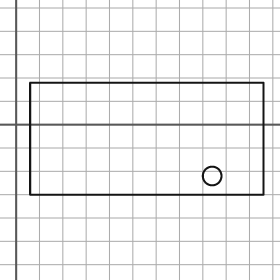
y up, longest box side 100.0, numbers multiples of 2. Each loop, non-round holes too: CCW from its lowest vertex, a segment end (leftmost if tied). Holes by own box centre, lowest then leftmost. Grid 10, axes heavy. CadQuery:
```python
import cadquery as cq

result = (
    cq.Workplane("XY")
    .moveTo(6.0, -30.0)
    .lineTo(106.0, -30.0)
    .lineTo(106.0, 18.0)
    .lineTo(6.0, 18.0)
    .close()
    .moveTo(84.0, -22.0)
    .circle(4.0)
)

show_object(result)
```